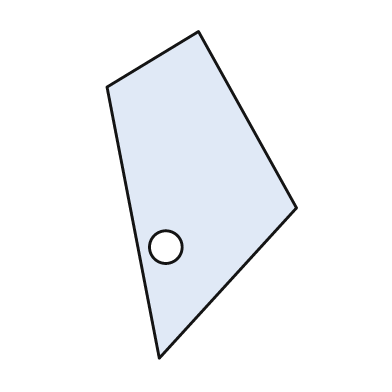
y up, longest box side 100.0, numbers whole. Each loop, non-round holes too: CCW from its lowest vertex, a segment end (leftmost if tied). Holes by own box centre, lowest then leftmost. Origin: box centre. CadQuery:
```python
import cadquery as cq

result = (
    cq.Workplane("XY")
    .moveTo(-13.0, -50.0)
    .lineTo(29.0, -4.0)
    .lineTo(-1.0, 50.0)
    .lineTo(-29.0, 33.0)
    .close()
    .moveTo(-11.0, -16.0)
    .circle(5.0)
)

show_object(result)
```